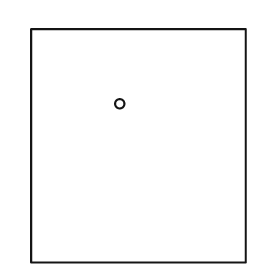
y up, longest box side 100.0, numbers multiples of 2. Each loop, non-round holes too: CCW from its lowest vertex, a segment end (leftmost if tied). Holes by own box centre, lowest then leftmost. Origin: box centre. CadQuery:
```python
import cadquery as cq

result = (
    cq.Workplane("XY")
    .moveTo(-46.0, -50.0)
    .lineTo(46.0, -50.0)
    .lineTo(46.0, 50.0)
    .lineTo(-46.0, 50.0)
    .close()
    .moveTo(-8.0, 18.0)
    .circle(2.0)
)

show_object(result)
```